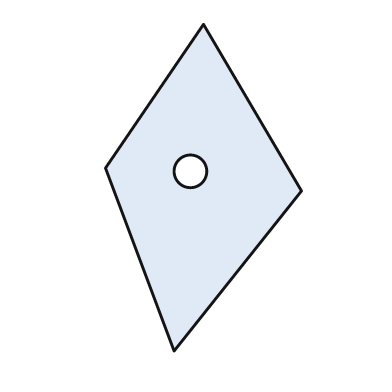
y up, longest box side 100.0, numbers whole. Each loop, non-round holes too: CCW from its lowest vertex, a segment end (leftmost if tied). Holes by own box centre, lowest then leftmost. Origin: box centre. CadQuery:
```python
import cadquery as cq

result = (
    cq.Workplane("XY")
    .moveTo(-9.0, -50.0)
    .lineTo(30.0, -1.0)
    .lineTo(0.0, 50.0)
    .lineTo(-30.0, 6.0)
    .close()
    .moveTo(-4.0, 5.0)
    .circle(5.0)
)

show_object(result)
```